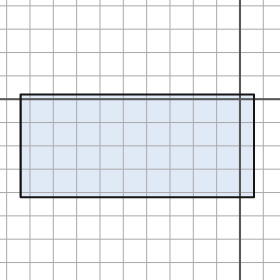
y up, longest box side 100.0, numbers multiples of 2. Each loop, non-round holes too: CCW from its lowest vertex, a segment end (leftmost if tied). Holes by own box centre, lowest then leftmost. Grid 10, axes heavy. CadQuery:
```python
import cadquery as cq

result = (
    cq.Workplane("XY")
    .moveTo(-94.0, -42.0)
    .lineTo(6.0, -42.0)
    .lineTo(6.0, 2.0)
    .lineTo(-94.0, 2.0)
    .close()
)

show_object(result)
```